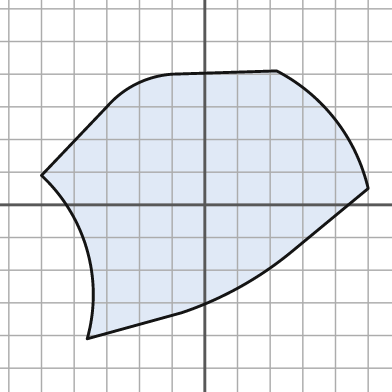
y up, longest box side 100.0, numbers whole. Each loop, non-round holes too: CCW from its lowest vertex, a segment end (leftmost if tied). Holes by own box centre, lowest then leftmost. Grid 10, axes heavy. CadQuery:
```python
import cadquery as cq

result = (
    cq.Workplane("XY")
    .moveTo(-36.0, -41.0)
    .lineTo(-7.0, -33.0)
    .threePointArc((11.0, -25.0), (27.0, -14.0))
    .lineTo(50.0, 5.0)
    .threePointArc((40.0, 26.0), (22.0, 41.0))
    .lineTo(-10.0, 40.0)
    .threePointArc((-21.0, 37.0), (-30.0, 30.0))
    .lineTo(-50.0, 9.0)
    .threePointArc((-36.0, -14.0), (-36.0, -41.0))
    .close()
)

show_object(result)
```